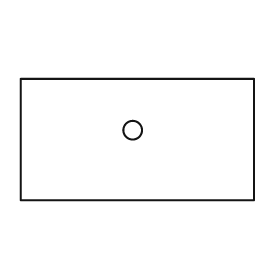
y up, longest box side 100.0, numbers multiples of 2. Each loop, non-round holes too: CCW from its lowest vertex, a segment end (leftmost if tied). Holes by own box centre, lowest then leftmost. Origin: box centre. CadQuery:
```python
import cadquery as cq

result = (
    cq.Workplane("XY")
    .moveTo(-50.0, -26.0)
    .lineTo(50.0, -26.0)
    .lineTo(50.0, 26.0)
    .lineTo(-50.0, 26.0)
    .close()
    .moveTo(-2.0, 4.0)
    .circle(4.0)
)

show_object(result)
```